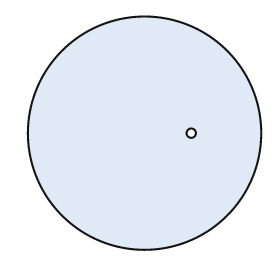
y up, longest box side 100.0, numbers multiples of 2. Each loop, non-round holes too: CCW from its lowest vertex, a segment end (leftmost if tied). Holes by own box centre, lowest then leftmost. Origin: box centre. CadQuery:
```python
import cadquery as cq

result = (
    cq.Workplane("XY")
    .moveTo(0.0, 0.0)
    .circle(50.0)
    .moveTo(20.0, 0.0)
    .circle(2.0)
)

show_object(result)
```